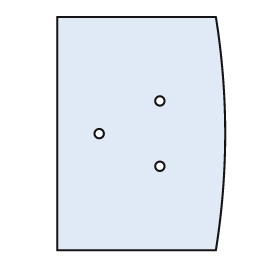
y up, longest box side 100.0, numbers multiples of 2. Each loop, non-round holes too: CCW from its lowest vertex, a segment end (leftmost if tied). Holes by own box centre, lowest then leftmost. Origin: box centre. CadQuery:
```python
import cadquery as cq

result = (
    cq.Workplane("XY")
    .moveTo(-36.0, -50.0)
    .lineTo(32.0, -50.0)
    .threePointArc((36.0, 0.0), (32.0, 50.0))
    .lineTo(-36.0, 50.0)
    .close()
    .moveTo(8.0, -14.0)
    .circle(2.0)
    .moveTo(-18.0, 0.0)
    .circle(2.0)
    .moveTo(8.0, 14.0)
    .circle(2.0)
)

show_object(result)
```